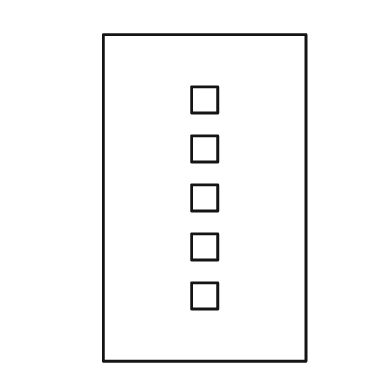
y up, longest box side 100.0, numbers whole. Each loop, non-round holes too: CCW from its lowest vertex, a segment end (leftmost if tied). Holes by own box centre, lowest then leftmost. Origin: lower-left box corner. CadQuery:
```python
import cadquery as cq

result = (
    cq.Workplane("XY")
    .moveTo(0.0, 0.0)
    .lineTo(62.0, 0.0)
    .lineTo(62.0, 100.0)
    .lineTo(0.0, 100.0)
    .close()
    .moveTo(27.0, 16.0)
    .lineTo(35.0, 16.0)
    .lineTo(35.0, 24.0)
    .lineTo(27.0, 24.0)
    .close()
    .moveTo(27.0, 31.0)
    .lineTo(35.0, 31.0)
    .lineTo(35.0, 39.0)
    .lineTo(27.0, 39.0)
    .close()
    .moveTo(27.0, 46.0)
    .lineTo(35.0, 46.0)
    .lineTo(35.0, 54.0)
    .lineTo(27.0, 54.0)
    .close()
    .moveTo(27.0, 61.0)
    .lineTo(35.0, 61.0)
    .lineTo(35.0, 69.0)
    .lineTo(27.0, 69.0)
    .close()
    .moveTo(27.0, 76.0)
    .lineTo(35.0, 76.0)
    .lineTo(35.0, 84.0)
    .lineTo(27.0, 84.0)
    .close()
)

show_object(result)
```